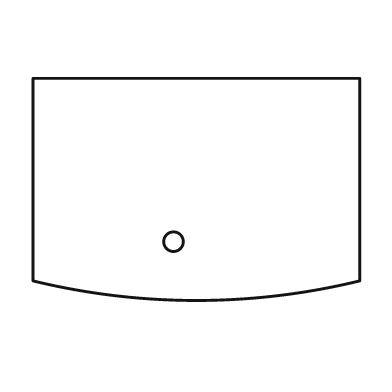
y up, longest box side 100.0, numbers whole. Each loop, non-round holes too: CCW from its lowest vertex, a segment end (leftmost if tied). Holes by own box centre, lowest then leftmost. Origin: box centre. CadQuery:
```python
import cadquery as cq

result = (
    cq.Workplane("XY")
    .moveTo(-50.0, -28.0)
    .threePointArc((0.0, -34.0), (50.0, -28.0))
    .lineTo(50.0, 34.0)
    .lineTo(-50.0, 34.0)
    .close()
    .moveTo(-7.0, -16.0)
    .circle(3.0)
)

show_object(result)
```